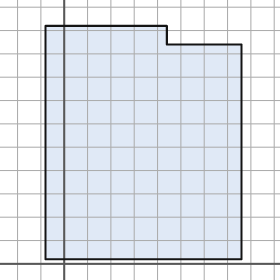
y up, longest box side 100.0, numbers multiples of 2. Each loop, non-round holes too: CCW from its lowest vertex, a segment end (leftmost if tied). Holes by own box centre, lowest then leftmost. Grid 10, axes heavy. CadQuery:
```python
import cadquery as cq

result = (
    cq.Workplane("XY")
    .moveTo(-8.0, 2.0)
    .lineTo(76.0, 2.0)
    .lineTo(76.0, 94.0)
    .lineTo(44.0, 94.0)
    .lineTo(44.0, 102.0)
    .lineTo(-8.0, 102.0)
    .close()
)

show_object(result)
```